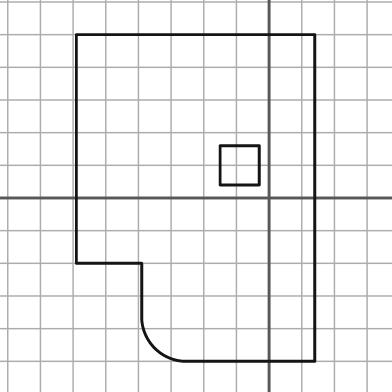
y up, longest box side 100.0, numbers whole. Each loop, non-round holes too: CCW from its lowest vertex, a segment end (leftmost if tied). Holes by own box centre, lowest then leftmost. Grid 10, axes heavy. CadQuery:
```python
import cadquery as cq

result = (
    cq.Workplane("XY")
    .moveTo(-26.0, -50.0)
    .lineTo(14.0, -50.0)
    .lineTo(14.0, 50.0)
    .lineTo(-59.0, 50.0)
    .lineTo(-59.0, -20.0)
    .lineTo(-39.0, -20.0)
    .lineTo(-39.0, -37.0)
    .threePointArc((-35.0, -46.0), (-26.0, -50.0))
    .close()
    .moveTo(-15.0, 4.0)
    .lineTo(-3.0, 4.0)
    .lineTo(-3.0, 16.0)
    .lineTo(-15.0, 16.0)
    .close()
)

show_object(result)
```